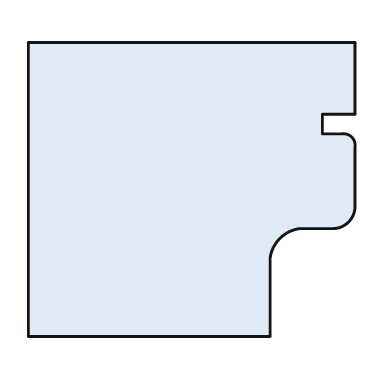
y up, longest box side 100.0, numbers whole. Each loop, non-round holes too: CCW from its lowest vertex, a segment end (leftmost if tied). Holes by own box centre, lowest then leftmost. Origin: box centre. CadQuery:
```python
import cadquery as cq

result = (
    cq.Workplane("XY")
    .moveTo(-50.0, -45.0)
    .lineTo(24.0, -45.0)
    .lineTo(24.0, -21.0)
    .threePointArc((27.0, -15.0), (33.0, -12.0))
    .lineTo(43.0, -12.0)
    .threePointArc((48.0, -10.0), (50.0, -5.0))
    .lineTo(50.0, 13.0)
    .threePointArc((49.0, 16.0), (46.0, 17.0))
    .lineTo(40.0, 17.0)
    .lineTo(40.0, 23.0)
    .lineTo(50.0, 23.0)
    .lineTo(50.0, 45.0)
    .lineTo(-50.0, 45.0)
    .close()
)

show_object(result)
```